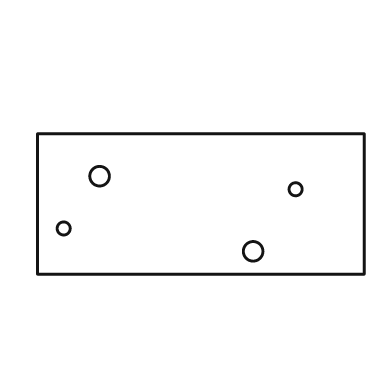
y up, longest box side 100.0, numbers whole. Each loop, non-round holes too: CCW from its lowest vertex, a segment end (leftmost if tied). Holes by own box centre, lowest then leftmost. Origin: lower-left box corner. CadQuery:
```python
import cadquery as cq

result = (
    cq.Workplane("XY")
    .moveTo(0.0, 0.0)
    .lineTo(100.0, 0.0)
    .lineTo(100.0, 43.0)
    .lineTo(0.0, 43.0)
    .close()
    .moveTo(66.0, 7.0)
    .circle(3.0)
    .moveTo(8.0, 14.0)
    .circle(2.0)
    .moveTo(79.0, 26.0)
    .circle(2.0)
    .moveTo(19.0, 30.0)
    .circle(3.0)
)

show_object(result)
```